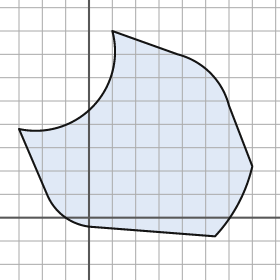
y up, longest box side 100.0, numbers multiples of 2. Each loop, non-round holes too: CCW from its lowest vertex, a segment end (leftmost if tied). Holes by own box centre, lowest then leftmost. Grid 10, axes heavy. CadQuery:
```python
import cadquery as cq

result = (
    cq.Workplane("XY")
    .moveTo(54.0, -8.0)
    .threePointArc((64.0, 6.0), (70.0, 22.0))
    .lineTo(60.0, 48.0)
    .threePointArc((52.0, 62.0), (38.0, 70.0))
    .lineTo(10.0, 80.0)
    .threePointArc((2.0, 48.0), (-30.0, 38.0))
    .lineTo(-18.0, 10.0)
    .threePointArc((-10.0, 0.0), (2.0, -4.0))
    .close()
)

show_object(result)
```